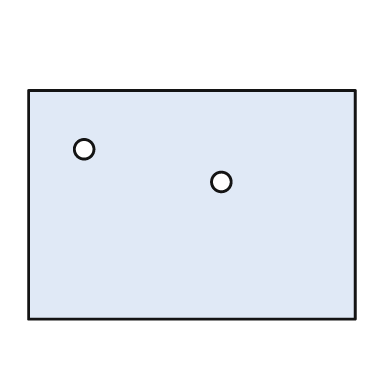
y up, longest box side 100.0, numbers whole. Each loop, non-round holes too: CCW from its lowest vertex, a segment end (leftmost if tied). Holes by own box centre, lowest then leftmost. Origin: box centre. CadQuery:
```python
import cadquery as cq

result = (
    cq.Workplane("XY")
    .moveTo(-50.0, -35.0)
    .lineTo(50.0, -35.0)
    .lineTo(50.0, 35.0)
    .lineTo(-50.0, 35.0)
    .close()
    .moveTo(9.0, 7.0)
    .circle(3.0)
    .moveTo(-33.0, 17.0)
    .circle(3.0)
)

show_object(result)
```